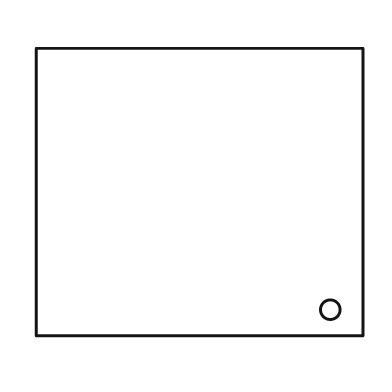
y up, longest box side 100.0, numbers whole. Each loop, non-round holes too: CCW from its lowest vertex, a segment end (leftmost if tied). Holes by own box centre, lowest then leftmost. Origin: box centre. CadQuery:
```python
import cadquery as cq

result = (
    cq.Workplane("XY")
    .moveTo(-50.0, -44.0)
    .lineTo(50.0, -44.0)
    .lineTo(50.0, 44.0)
    .lineTo(-50.0, 44.0)
    .close()
    .moveTo(40.0, -36.0)
    .circle(3.0)
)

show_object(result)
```